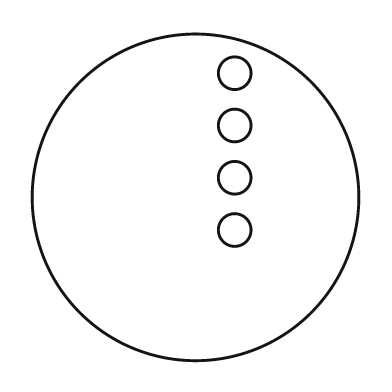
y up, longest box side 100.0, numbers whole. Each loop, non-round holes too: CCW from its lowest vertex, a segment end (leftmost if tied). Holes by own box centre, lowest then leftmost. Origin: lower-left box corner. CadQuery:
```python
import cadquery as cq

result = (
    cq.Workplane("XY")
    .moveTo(50.0, 50.0)
    .circle(50.0)
    .moveTo(62.0, 40.0)
    .circle(5.0)
    .moveTo(62.0, 56.0)
    .circle(5.0)
    .moveTo(62.0, 72.0)
    .circle(5.0)
    .moveTo(62.0, 88.0)
    .circle(5.0)
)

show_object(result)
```